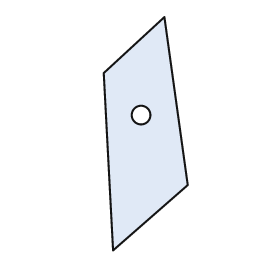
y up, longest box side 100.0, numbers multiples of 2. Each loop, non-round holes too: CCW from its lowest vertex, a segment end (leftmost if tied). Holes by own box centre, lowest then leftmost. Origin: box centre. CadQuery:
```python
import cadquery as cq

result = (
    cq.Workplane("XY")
    .moveTo(-14.0, -50.0)
    .lineTo(18.0, -22.0)
    .lineTo(8.0, 50.0)
    .lineTo(-18.0, 26.0)
    .close()
    .moveTo(-2.0, 8.0)
    .circle(4.0)
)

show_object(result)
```